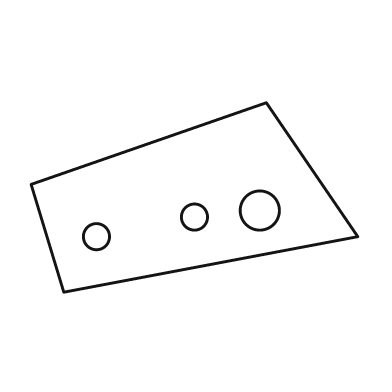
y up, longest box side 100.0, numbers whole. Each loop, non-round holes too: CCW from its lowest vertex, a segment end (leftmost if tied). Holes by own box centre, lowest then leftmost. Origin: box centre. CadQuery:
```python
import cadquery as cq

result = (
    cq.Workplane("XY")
    .moveTo(-40.0, -29.0)
    .lineTo(50.0, -12.0)
    .lineTo(22.0, 29.0)
    .lineTo(-50.0, 4.0)
    .close()
    .moveTo(-30.0, -12.0)
    .circle(4.0)
    .moveTo(0.0, -6.0)
    .circle(4.0)
    .moveTo(20.0, -4.0)
    .circle(6.0)
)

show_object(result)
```